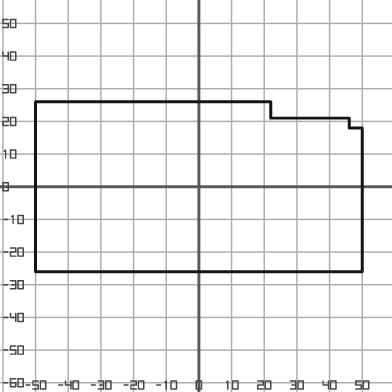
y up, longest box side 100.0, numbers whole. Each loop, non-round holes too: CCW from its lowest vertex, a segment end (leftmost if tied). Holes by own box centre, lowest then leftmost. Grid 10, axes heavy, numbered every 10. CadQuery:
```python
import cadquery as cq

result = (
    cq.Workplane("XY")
    .moveTo(-50.0, -26.0)
    .lineTo(50.0, -26.0)
    .lineTo(50.0, 18.0)
    .lineTo(46.0, 18.0)
    .lineTo(46.0, 21.0)
    .lineTo(22.0, 21.0)
    .lineTo(22.0, 26.0)
    .lineTo(-50.0, 26.0)
    .close()
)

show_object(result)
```